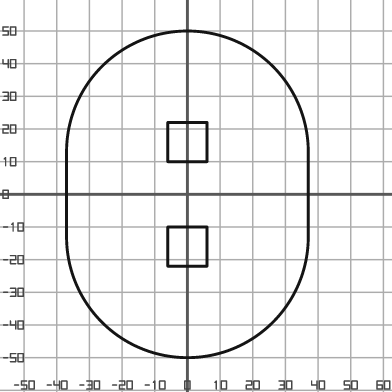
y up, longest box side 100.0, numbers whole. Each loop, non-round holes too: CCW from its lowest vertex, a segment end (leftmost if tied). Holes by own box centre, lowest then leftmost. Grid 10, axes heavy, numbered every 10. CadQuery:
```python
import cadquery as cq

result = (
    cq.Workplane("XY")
    .moveTo(-37.0, -13.0)
    .threePointArc((0.0, -50.0), (37.0, -13.0))
    .lineTo(37.0, 13.0)
    .threePointArc((0.0, 50.0), (-37.0, 13.0))
    .close()
    .moveTo(-6.0, -22.0)
    .lineTo(6.0, -22.0)
    .lineTo(6.0, -10.0)
    .lineTo(-6.0, -10.0)
    .close()
    .moveTo(-6.0, 10.0)
    .lineTo(6.0, 10.0)
    .lineTo(6.0, 22.0)
    .lineTo(-6.0, 22.0)
    .close()
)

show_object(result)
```